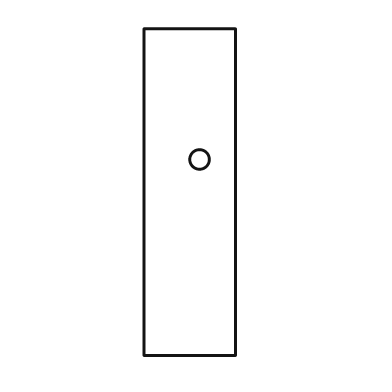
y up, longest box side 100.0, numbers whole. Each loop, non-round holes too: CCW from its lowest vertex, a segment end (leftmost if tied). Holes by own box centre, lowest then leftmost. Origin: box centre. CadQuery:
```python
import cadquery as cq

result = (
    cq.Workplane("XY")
    .moveTo(-14.0, -50.0)
    .lineTo(14.0, -50.0)
    .lineTo(14.0, 50.0)
    .lineTo(-14.0, 50.0)
    .close()
    .moveTo(3.0, 10.0)
    .circle(3.0)
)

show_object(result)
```